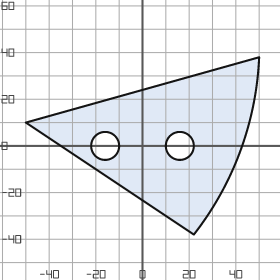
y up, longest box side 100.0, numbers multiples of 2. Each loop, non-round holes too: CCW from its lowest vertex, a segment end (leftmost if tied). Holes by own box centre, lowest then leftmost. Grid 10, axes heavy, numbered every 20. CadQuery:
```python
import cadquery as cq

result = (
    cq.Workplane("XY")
    .moveTo(22.0, -38.0)
    .threePointArc((42.0, -2.0), (50.0, 38.0))
    .lineTo(-50.0, 10.0)
    .close()
    .moveTo(-16.0, 0.0)
    .circle(6.0)
    .moveTo(16.0, 0.0)
    .circle(6.0)
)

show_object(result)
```